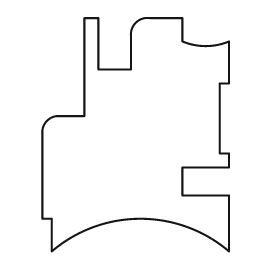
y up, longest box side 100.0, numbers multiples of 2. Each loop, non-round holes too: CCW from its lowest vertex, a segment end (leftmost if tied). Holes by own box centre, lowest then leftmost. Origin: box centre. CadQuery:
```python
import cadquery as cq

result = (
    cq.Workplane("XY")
    .moveTo(-36.0, -50.0)
    .threePointArc((2.0, -36.0), (40.0, -50.0))
    .lineTo(40.0, -26.0)
    .lineTo(20.0, -26.0)
    .lineTo(20.0, -14.0)
    .lineTo(40.0, -14.0)
    .lineTo(40.0, -8.0)
    .lineTo(36.0, -8.0)
    .lineTo(36.0, 22.0)
    .lineTo(40.0, 22.0)
    .lineTo(40.0, 40.0)
    .threePointArc((30.0, 38.0), (20.0, 40.0))
    .lineTo(20.0, 50.0)
    .lineTo(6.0, 50.0)
    .threePointArc((0.0, 48.0), (-2.0, 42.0))
    .lineTo(-2.0, 28.0)
    .lineTo(-16.0, 28.0)
    .lineTo(-16.0, 50.0)
    .lineTo(-22.0, 50.0)
    .lineTo(-22.0, 8.0)
    .lineTo(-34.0, 8.0)
    .threePointArc((-38.0, 6.0), (-40.0, 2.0))
    .lineTo(-40.0, -36.0)
    .lineTo(-36.0, -36.0)
    .close()
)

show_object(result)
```